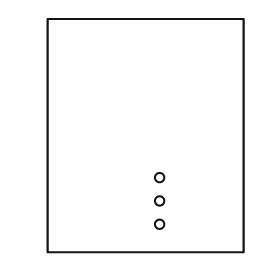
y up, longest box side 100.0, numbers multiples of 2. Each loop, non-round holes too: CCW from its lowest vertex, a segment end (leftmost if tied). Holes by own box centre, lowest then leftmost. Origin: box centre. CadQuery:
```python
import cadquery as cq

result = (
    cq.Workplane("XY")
    .moveTo(-42.0, -50.0)
    .lineTo(42.0, -50.0)
    .lineTo(42.0, 50.0)
    .lineTo(-42.0, 50.0)
    .close()
    .moveTo(6.0, -38.0)
    .circle(2.0)
    .moveTo(6.0, -28.0)
    .circle(2.0)
    .moveTo(6.0, -18.0)
    .circle(2.0)
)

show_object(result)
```